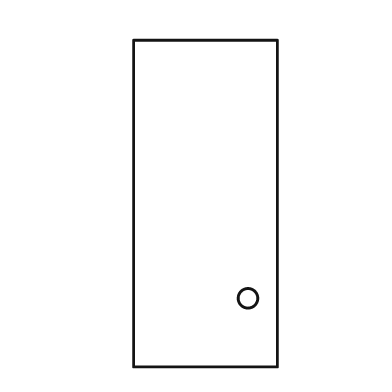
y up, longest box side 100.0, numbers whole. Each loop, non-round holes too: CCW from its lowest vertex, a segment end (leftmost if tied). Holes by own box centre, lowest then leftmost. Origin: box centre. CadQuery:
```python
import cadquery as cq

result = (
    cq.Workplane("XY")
    .moveTo(-22.0, -50.0)
    .lineTo(22.0, -50.0)
    .lineTo(22.0, 50.0)
    .lineTo(-22.0, 50.0)
    .close()
    .moveTo(13.0, -29.0)
    .circle(3.0)
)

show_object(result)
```